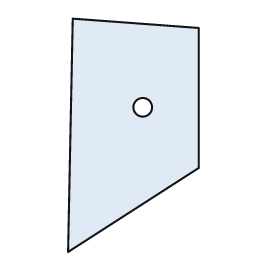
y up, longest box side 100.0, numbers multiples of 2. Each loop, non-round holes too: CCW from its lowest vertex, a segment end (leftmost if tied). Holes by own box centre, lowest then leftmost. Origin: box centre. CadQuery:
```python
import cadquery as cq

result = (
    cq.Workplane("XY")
    .moveTo(-28.0, -50.0)
    .lineTo(28.0, -14.0)
    .lineTo(28.0, 46.0)
    .lineTo(-26.0, 50.0)
    .close()
    .moveTo(4.0, 12.0)
    .circle(4.0)
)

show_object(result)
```